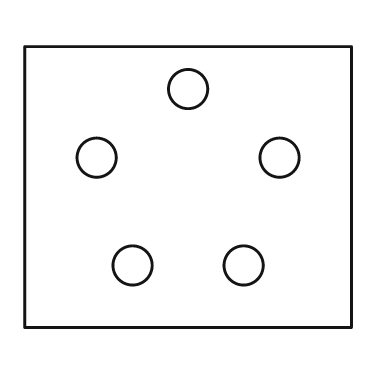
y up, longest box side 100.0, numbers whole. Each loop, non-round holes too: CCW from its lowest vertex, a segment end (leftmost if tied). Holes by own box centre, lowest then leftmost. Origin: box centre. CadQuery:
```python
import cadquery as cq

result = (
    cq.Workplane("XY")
    .moveTo(-50.0, -43.0)
    .lineTo(50.0, -43.0)
    .lineTo(50.0, 43.0)
    .lineTo(-50.0, 43.0)
    .close()
    .moveTo(-17.0, -24.0)
    .circle(6.0)
    .moveTo(17.0, -24.0)
    .circle(6.0)
    .moveTo(-28.0, 9.0)
    .circle(6.0)
    .moveTo(28.0, 9.0)
    .circle(6.0)
    .moveTo(0.0, 30.0)
    .circle(6.0)
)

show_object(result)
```